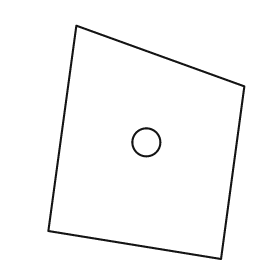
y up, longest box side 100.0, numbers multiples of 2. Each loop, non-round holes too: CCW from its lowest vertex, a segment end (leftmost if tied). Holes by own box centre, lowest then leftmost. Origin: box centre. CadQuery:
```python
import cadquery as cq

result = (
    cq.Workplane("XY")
    .moveTo(32.0, -50.0)
    .lineTo(42.0, 24.0)
    .lineTo(-30.0, 50.0)
    .lineTo(-42.0, -38.0)
    .close()
    .moveTo(0.0, 0.0)
    .circle(6.0)
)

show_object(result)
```